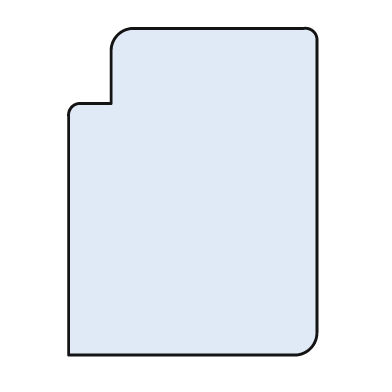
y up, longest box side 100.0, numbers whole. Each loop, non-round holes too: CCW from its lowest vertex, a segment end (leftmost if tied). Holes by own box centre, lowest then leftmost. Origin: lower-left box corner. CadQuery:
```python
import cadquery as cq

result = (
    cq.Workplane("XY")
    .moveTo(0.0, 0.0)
    .lineTo(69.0, 0.0)
    .threePointArc((74.0, 2.0), (76.0, 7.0))
    .lineTo(76.0, 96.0)
    .threePointArc((75.0, 99.0), (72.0, 100.0))
    .lineTo(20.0, 100.0)
    .threePointArc((15.0, 98.0), (13.0, 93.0))
    .lineTo(13.0, 77.0)
    .lineTo(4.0, 77.0)
    .threePointArc((1.0, 76.0), (0.0, 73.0))
    .close()
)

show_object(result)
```